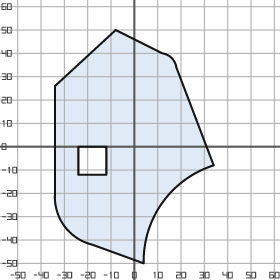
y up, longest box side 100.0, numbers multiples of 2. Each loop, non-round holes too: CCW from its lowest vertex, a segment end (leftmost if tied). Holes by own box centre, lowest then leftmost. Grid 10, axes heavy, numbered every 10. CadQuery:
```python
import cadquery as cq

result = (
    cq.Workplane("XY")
    .moveTo(4.0, -50.0)
    .threePointArc((12.0, -24.0), (34.0, -8.0))
    .lineTo(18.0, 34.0)
    .threePointArc((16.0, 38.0), (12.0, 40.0))
    .lineTo(-8.0, 50.0)
    .lineTo(-34.0, 26.0)
    .lineTo(-34.0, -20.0)
    .threePointArc((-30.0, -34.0), (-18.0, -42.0))
    .close()
    .moveTo(-24.0, -12.0)
    .lineTo(-12.0, -12.0)
    .lineTo(-12.0, 0.0)
    .lineTo(-24.0, 0.0)
    .close()
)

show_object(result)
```